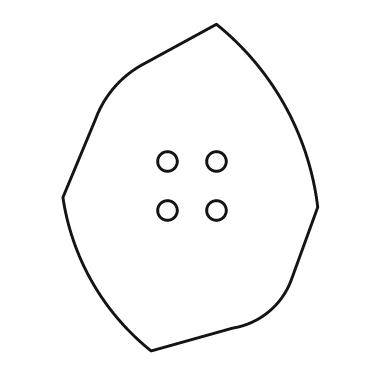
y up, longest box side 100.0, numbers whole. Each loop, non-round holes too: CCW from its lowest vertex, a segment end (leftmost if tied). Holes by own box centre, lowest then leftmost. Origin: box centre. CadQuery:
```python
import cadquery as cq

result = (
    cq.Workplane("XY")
    .moveTo(-12.0, -50.0)
    .lineTo(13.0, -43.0)
    .threePointArc((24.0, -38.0), (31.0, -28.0))
    .lineTo(39.0, -6.0)
    .threePointArc((29.0, 25.0), (8.0, 50.0))
    .lineTo(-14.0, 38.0)
    .threePointArc((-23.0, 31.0), (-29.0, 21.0))
    .lineTo(-39.0, -3.0)
    .threePointArc((-30.0, -29.0), (-12.0, -50.0))
    .close()
    .moveTo(-7.0, -7.0)
    .circle(3.0)
    .moveTo(8.0, -7.0)
    .circle(3.0)
    .moveTo(-7.0, 8.0)
    .circle(3.0)
    .moveTo(8.0, 8.0)
    .circle(3.0)
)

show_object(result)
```